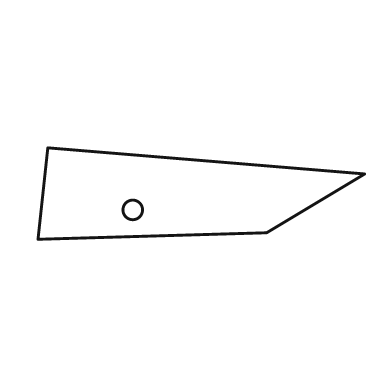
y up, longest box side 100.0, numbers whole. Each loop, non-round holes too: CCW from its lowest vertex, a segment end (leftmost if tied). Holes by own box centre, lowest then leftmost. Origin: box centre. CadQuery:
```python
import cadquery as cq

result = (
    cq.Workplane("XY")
    .moveTo(-50.0, -14.0)
    .lineTo(20.0, -12.0)
    .lineTo(50.0, 6.0)
    .lineTo(-47.0, 14.0)
    .close()
    .moveTo(-21.0, -5.0)
    .circle(3.0)
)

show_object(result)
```